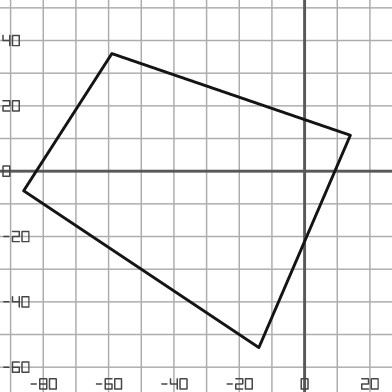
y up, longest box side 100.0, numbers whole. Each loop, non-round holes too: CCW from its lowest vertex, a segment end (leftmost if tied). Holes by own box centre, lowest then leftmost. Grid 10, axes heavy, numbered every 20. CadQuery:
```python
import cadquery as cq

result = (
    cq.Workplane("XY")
    .moveTo(-14.0, -54.0)
    .lineTo(14.0, 11.0)
    .lineTo(-59.0, 36.0)
    .lineTo(-86.0, -6.0)
    .close()
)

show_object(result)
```